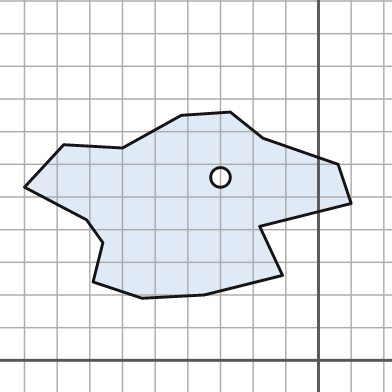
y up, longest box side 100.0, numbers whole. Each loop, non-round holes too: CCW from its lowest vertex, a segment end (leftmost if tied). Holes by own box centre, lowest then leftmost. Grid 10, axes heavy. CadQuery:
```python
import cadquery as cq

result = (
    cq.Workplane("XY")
    .moveTo(-54.0, 19.0)
    .lineTo(-35.0, 20.0)
    .lineTo(-11.0, 26.0)
    .lineTo(-18.0, 41.0)
    .lineTo(10.0, 48.0)
    .lineTo(6.0, 60.0)
    .lineTo(-17.0, 68.0)
    .lineTo(-27.0, 76.0)
    .lineTo(-42.0, 75.0)
    .lineTo(-60.0, 65.0)
    .lineTo(-78.0, 66.0)
    .lineTo(-90.0, 53.0)
    .lineTo(-71.0, 43.0)
    .lineTo(-66.0, 36.0)
    .lineTo(-69.0, 24.0)
    .close()
    .moveTo(-30.0, 56.0)
    .circle(3.0)
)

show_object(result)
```